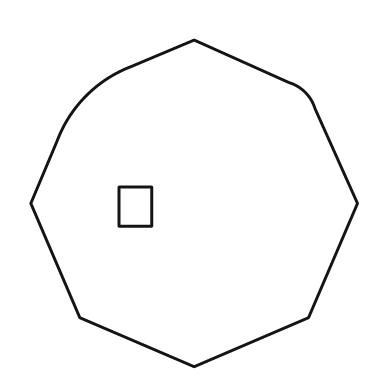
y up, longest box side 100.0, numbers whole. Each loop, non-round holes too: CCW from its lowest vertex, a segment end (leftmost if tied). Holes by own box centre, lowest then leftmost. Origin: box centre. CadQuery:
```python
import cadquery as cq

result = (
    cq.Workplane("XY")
    .moveTo(0.0, -50.0)
    .lineTo(35.0, -35.0)
    .lineTo(50.0, 0.0)
    .lineTo(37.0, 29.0)
    .threePointArc((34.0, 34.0), (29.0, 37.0))
    .lineTo(0.0, 50.0)
    .lineTo(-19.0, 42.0)
    .threePointArc((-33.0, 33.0), (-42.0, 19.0))
    .lineTo(-50.0, 0.0)
    .lineTo(-35.0, -35.0)
    .close()
    .moveTo(-23.0, -7.0)
    .lineTo(-13.0, -7.0)
    .lineTo(-13.0, 5.0)
    .lineTo(-23.0, 5.0)
    .close()
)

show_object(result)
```